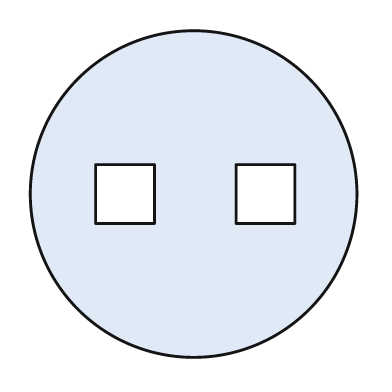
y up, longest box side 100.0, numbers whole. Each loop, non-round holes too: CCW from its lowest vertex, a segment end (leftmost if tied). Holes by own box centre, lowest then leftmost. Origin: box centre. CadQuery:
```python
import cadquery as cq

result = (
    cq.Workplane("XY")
    .moveTo(0.0, 0.0)
    .circle(50.0)
    .moveTo(-30.0, -9.0)
    .lineTo(-12.0, -9.0)
    .lineTo(-12.0, 9.0)
    .lineTo(-30.0, 9.0)
    .close()
    .moveTo(13.0, -9.0)
    .lineTo(31.0, -9.0)
    .lineTo(31.0, 9.0)
    .lineTo(13.0, 9.0)
    .close()
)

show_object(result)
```